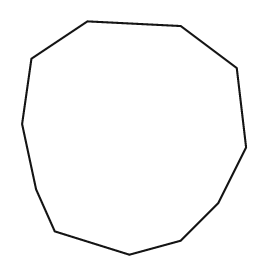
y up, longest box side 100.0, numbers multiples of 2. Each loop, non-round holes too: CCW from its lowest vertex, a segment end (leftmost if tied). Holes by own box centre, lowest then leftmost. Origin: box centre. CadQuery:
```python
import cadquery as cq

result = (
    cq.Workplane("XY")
    .moveTo(-2.0, -50.0)
    .lineTo(20.0, -44.0)
    .lineTo(36.0, -28.0)
    .lineTo(48.0, -4.0)
    .lineTo(44.0, 30.0)
    .lineTo(20.0, 48.0)
    .lineTo(-20.0, 50.0)
    .lineTo(-44.0, 34.0)
    .lineTo(-48.0, 6.0)
    .lineTo(-42.0, -22.0)
    .lineTo(-34.0, -40.0)
    .close()
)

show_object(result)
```